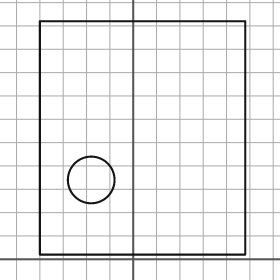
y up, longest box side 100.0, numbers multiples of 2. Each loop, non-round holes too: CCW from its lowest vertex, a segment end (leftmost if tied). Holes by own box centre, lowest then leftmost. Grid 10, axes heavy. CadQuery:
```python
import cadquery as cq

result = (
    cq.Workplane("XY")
    .moveTo(-40.0, 2.0)
    .lineTo(48.0, 2.0)
    .lineTo(48.0, 102.0)
    .lineTo(-40.0, 102.0)
    .close()
    .moveTo(-18.0, 34.0)
    .circle(10.0)
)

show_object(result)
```